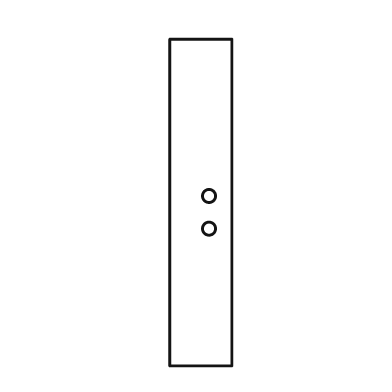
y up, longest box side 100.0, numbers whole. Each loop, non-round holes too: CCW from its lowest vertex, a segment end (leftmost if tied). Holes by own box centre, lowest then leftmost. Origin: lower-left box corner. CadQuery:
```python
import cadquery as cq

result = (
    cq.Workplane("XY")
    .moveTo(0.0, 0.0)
    .lineTo(19.0, 0.0)
    .lineTo(19.0, 100.0)
    .lineTo(0.0, 100.0)
    .close()
    .moveTo(12.0, 42.0)
    .circle(2.0)
    .moveTo(12.0, 52.0)
    .circle(2.0)
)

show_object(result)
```